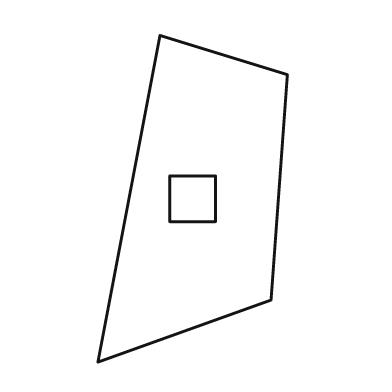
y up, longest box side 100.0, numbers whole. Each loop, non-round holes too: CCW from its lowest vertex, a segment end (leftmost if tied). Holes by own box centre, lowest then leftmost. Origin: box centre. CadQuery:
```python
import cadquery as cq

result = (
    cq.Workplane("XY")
    .moveTo(-29.0, -50.0)
    .lineTo(24.0, -31.0)
    .lineTo(29.0, 38.0)
    .lineTo(-10.0, 50.0)
    .close()
    .moveTo(-7.0, -7.0)
    .lineTo(7.0, -7.0)
    .lineTo(7.0, 7.0)
    .lineTo(-7.0, 7.0)
    .close()
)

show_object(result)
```